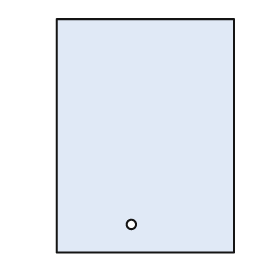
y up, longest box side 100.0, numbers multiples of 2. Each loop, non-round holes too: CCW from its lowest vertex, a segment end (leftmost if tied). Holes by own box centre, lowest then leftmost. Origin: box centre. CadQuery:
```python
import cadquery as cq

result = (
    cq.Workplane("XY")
    .moveTo(-38.0, -50.0)
    .lineTo(38.0, -50.0)
    .lineTo(38.0, 50.0)
    .lineTo(-38.0, 50.0)
    .close()
    .moveTo(-6.0, -38.0)
    .circle(2.0)
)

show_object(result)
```